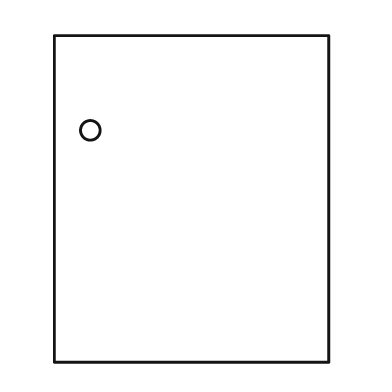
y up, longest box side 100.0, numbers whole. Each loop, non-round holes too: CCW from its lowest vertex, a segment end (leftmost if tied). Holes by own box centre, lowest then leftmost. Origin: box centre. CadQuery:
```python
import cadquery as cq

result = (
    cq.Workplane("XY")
    .moveTo(-42.0, -50.0)
    .lineTo(42.0, -50.0)
    .lineTo(42.0, 50.0)
    .lineTo(-42.0, 50.0)
    .close()
    .moveTo(-31.0, 21.0)
    .circle(3.0)
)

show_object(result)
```